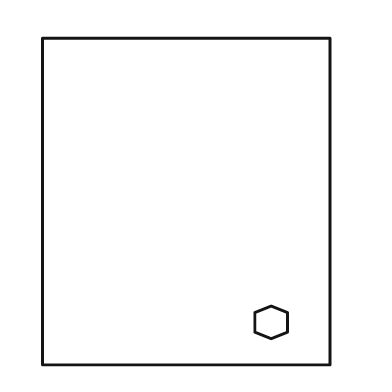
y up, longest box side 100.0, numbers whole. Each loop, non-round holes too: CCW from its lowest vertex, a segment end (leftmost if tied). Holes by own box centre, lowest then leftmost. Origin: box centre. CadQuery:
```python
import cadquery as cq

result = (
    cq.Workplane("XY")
    .moveTo(-44.0, -50.0)
    .lineTo(44.0, -50.0)
    .lineTo(44.0, 50.0)
    .lineTo(-44.0, 50.0)
    .close()
    .moveTo(26.0, -42.0)
    .lineTo(31.0, -40.0)
    .lineTo(31.0, -34.0)
    .lineTo(26.0, -32.0)
    .lineTo(21.0, -34.0)
    .lineTo(21.0, -40.0)
    .close()
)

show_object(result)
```